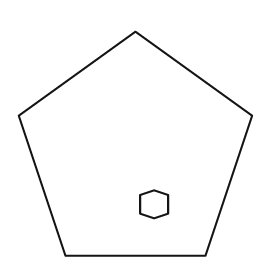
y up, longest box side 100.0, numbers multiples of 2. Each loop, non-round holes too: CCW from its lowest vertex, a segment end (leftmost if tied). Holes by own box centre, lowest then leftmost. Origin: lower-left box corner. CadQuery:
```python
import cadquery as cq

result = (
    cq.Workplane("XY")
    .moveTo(20.0, 0.0)
    .lineTo(80.0, 0.0)
    .lineTo(100.0, 60.0)
    .lineTo(50.0, 96.0)
    .lineTo(0.0, 60.0)
    .close()
    .moveTo(58.0, 16.0)
    .lineTo(64.0, 18.0)
    .lineTo(64.0, 26.0)
    .lineTo(58.0, 28.0)
    .lineTo(52.0, 26.0)
    .lineTo(52.0, 18.0)
    .close()
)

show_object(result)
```